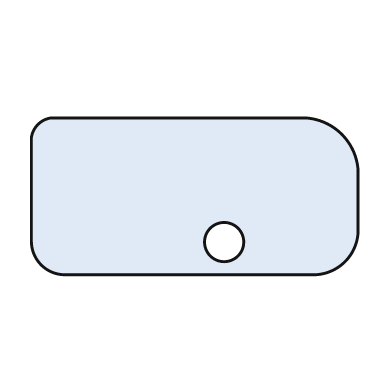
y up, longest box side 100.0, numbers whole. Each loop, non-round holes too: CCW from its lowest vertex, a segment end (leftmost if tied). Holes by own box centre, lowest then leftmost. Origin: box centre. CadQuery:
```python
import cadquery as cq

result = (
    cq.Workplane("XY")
    .moveTo(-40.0, -24.0)
    .lineTo(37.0, -24.0)
    .threePointArc((46.0, -20.0), (50.0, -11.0))
    .lineTo(50.0, 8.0)
    .threePointArc((45.0, 19.0), (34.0, 24.0))
    .lineTo(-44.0, 24.0)
    .threePointArc((-48.0, 22.0), (-50.0, 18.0))
    .lineTo(-50.0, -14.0)
    .threePointArc((-47.0, -21.0), (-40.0, -24.0))
    .close()
    .moveTo(9.0, -14.0)
    .circle(6.0)
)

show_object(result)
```